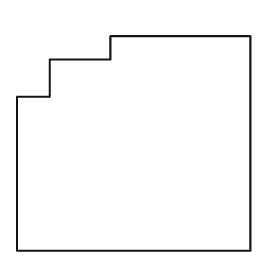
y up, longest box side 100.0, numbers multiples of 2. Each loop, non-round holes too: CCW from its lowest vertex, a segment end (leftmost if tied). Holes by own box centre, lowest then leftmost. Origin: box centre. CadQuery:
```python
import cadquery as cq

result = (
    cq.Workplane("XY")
    .moveTo(-50.0, -46.0)
    .lineTo(50.0, -46.0)
    .lineTo(50.0, 46.0)
    .lineTo(-10.0, 46.0)
    .lineTo(-10.0, 36.0)
    .lineTo(-36.0, 36.0)
    .lineTo(-36.0, 20.0)
    .lineTo(-50.0, 20.0)
    .close()
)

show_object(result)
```